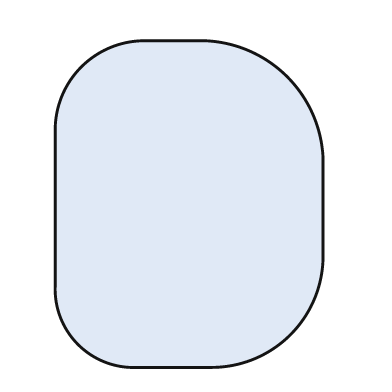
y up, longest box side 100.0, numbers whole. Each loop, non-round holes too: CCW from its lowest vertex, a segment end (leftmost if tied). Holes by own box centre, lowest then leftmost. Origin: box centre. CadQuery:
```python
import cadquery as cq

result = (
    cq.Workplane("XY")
    .moveTo(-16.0, -50.0)
    .lineTo(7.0, -50.0)
    .threePointArc((31.0, -40.0), (41.0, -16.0))
    .lineTo(41.0, 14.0)
    .threePointArc((30.0, 39.0), (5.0, 50.0))
    .lineTo(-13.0, 50.0)
    .threePointArc((-33.0, 42.0), (-41.0, 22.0))
    .lineTo(-41.0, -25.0)
    .threePointArc((-34.0, -43.0), (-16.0, -50.0))
    .close()
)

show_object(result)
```